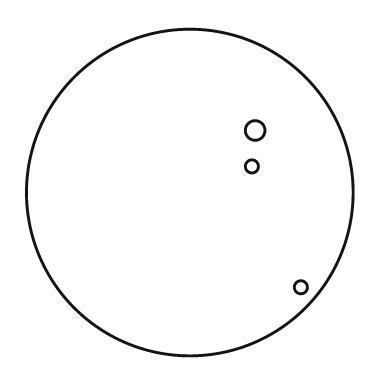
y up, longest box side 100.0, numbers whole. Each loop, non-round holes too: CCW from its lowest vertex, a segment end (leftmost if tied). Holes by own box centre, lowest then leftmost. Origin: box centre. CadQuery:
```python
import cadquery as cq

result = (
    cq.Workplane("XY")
    .moveTo(0.0, 0.0)
    .circle(50.0)
    .moveTo(34.0, -29.0)
    .circle(2.0)
    .moveTo(19.0, 8.0)
    .circle(2.0)
    .moveTo(20.0, 19.0)
    .circle(3.0)
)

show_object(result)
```